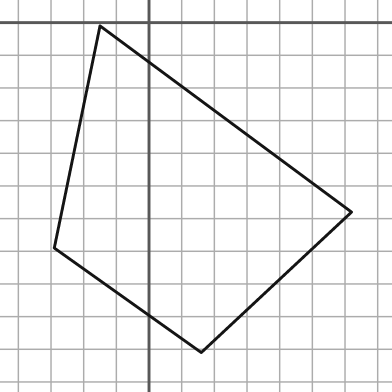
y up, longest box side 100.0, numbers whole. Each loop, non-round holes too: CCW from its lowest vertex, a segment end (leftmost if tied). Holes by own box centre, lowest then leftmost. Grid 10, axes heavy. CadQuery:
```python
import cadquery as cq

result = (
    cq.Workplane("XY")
    .moveTo(16.0, -101.0)
    .lineTo(62.0, -58.0)
    .lineTo(-15.0, -1.0)
    .lineTo(-29.0, -69.0)
    .close()
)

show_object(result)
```